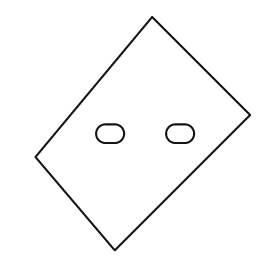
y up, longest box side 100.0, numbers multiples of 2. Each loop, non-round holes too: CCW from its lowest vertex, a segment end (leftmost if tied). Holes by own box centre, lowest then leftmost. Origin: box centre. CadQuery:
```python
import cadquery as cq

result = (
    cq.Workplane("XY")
    .moveTo(-12.0, -50.0)
    .lineTo(46.0, 8.0)
    .lineTo(4.0, 50.0)
    .lineTo(-46.0, -10.0)
    .close()
    .moveTo(-16.0, -4.0)
    .lineTo(-12.0, -4.0)
    .threePointArc((-8.0, 0.0), (-12.0, 4.0))
    .lineTo(-16.0, 4.0)
    .threePointArc((-20.0, 0.0), (-16.0, -4.0))
    .close()
    .moveTo(14.0, -4.0)
    .lineTo(18.0, -4.0)
    .threePointArc((22.0, 0.0), (18.0, 4.0))
    .lineTo(14.0, 4.0)
    .threePointArc((10.0, 0.0), (14.0, -4.0))
    .close()
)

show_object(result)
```